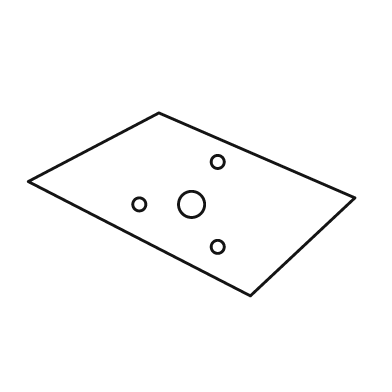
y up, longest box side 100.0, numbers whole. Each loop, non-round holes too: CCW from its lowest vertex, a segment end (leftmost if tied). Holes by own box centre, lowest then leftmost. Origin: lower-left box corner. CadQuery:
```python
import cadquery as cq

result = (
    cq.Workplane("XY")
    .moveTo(68.0, 0.0)
    .lineTo(100.0, 30.0)
    .lineTo(40.0, 56.0)
    .lineTo(0.0, 35.0)
    .close()
    .moveTo(58.0, 15.0)
    .circle(2.0)
    .moveTo(34.0, 28.0)
    .circle(2.0)
    .moveTo(50.0, 28.0)
    .circle(4.0)
    .moveTo(58.0, 41.0)
    .circle(2.0)
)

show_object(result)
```